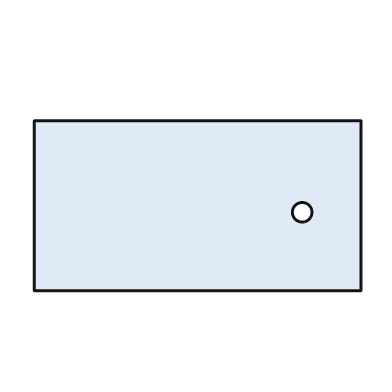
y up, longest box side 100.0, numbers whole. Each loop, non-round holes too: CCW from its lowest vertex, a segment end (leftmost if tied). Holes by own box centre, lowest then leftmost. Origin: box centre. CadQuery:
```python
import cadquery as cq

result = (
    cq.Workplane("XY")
    .moveTo(-50.0, -26.0)
    .lineTo(50.0, -26.0)
    .lineTo(50.0, 26.0)
    .lineTo(-50.0, 26.0)
    .close()
    .moveTo(32.0, -2.0)
    .circle(3.0)
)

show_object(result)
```